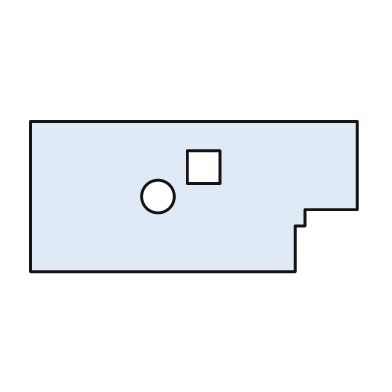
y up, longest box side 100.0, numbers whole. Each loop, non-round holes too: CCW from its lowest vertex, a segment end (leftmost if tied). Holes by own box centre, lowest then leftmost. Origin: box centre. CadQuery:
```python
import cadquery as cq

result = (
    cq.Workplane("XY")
    .moveTo(-50.0, -23.0)
    .lineTo(31.0, -23.0)
    .lineTo(31.0, -9.0)
    .lineTo(34.0, -9.0)
    .lineTo(34.0, -4.0)
    .lineTo(50.0, -4.0)
    .lineTo(50.0, 23.0)
    .lineTo(-50.0, 23.0)
    .close()
    .moveTo(-11.0, 0.0)
    .circle(5.0)
    .moveTo(-2.0, 4.0)
    .lineTo(8.0, 4.0)
    .lineTo(8.0, 14.0)
    .lineTo(-2.0, 14.0)
    .close()
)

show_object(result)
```